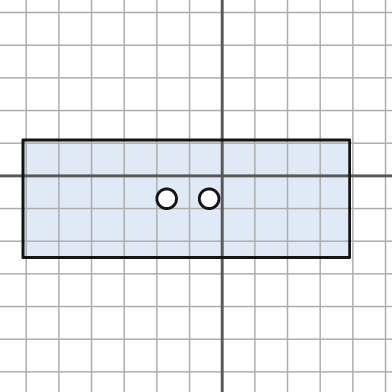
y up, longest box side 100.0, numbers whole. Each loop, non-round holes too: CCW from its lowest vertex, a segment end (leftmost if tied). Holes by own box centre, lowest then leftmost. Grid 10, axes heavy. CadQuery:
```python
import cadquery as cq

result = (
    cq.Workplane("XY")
    .moveTo(-61.0, -25.0)
    .lineTo(39.0, -25.0)
    .lineTo(39.0, 11.0)
    .lineTo(-61.0, 11.0)
    .close()
    .moveTo(-17.0, -7.0)
    .circle(3.0)
    .moveTo(-4.0, -7.0)
    .circle(3.0)
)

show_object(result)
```